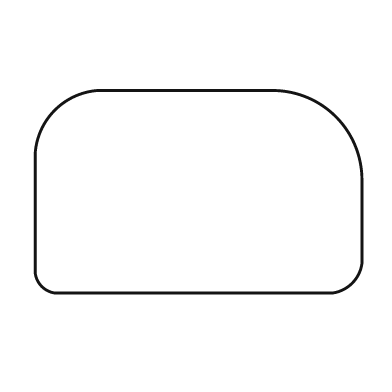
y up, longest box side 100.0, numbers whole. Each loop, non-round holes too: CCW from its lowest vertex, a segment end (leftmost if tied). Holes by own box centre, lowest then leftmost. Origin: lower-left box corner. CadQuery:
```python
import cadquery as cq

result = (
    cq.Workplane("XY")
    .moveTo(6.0, 0.0)
    .lineTo(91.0, 0.0)
    .threePointArc((97.0, 3.0), (100.0, 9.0))
    .lineTo(100.0, 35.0)
    .threePointArc((92.0, 54.0), (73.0, 62.0))
    .lineTo(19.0, 62.0)
    .threePointArc((6.0, 56.0), (0.0, 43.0))
    .lineTo(0.0, 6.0)
    .threePointArc((2.0, 2.0), (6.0, 0.0))
    .close()
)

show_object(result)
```